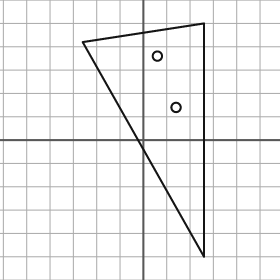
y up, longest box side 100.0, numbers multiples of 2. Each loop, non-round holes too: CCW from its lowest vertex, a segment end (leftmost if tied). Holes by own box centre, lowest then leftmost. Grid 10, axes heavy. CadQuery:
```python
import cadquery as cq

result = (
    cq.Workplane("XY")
    .moveTo(26.0, -50.0)
    .lineTo(26.0, 50.0)
    .lineTo(-26.0, 42.0)
    .close()
    .moveTo(14.0, 14.0)
    .circle(2.0)
    .moveTo(6.0, 36.0)
    .circle(2.0)
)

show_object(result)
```